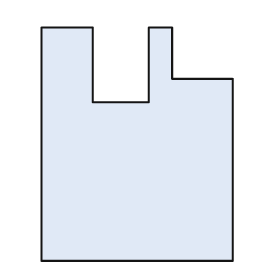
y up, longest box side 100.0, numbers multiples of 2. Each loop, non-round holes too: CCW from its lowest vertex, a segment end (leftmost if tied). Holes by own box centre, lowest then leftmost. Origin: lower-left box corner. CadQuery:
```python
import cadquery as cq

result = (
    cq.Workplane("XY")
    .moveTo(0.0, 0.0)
    .lineTo(82.0, 0.0)
    .lineTo(82.0, 78.0)
    .lineTo(56.0, 78.0)
    .lineTo(56.0, 100.0)
    .lineTo(46.0, 100.0)
    .lineTo(46.0, 68.0)
    .lineTo(22.0, 68.0)
    .lineTo(22.0, 100.0)
    .lineTo(0.0, 100.0)
    .close()
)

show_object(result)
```